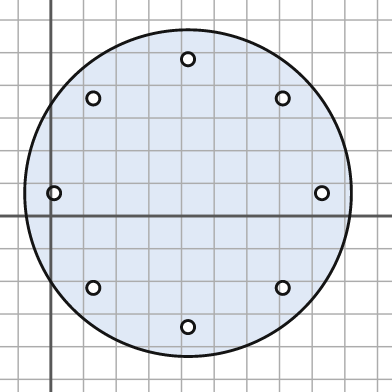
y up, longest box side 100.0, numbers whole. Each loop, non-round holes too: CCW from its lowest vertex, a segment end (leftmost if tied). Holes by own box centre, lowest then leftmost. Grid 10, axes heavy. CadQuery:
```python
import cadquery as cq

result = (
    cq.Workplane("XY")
    .moveTo(42.0, 7.0)
    .circle(50.0)
    .moveTo(42.0, -34.0)
    .circle(2.0)
    .moveTo(13.0, -22.0)
    .circle(2.0)
    .moveTo(71.0, -22.0)
    .circle(2.0)
    .moveTo(1.0, 7.0)
    .circle(2.0)
    .moveTo(83.0, 7.0)
    .circle(2.0)
    .moveTo(13.0, 36.0)
    .circle(2.0)
    .moveTo(71.0, 36.0)
    .circle(2.0)
    .moveTo(42.0, 48.0)
    .circle(2.0)
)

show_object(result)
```